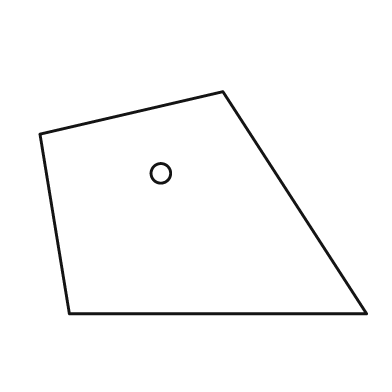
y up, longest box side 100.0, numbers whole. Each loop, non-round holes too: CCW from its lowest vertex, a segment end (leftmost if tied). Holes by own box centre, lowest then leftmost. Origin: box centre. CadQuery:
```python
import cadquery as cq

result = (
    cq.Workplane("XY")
    .moveTo(-41.0, -34.0)
    .lineTo(50.0, -34.0)
    .lineTo(6.0, 34.0)
    .lineTo(-50.0, 21.0)
    .close()
    .moveTo(-13.0, 9.0)
    .circle(3.0)
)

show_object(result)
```